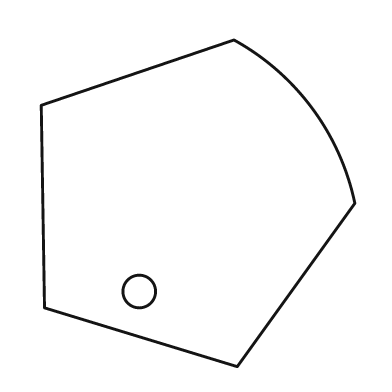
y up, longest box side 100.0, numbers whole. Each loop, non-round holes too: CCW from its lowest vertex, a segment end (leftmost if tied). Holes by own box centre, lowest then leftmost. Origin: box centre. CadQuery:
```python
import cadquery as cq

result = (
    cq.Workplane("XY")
    .moveTo(12.0, -50.0)
    .lineTo(48.0, 0.0)
    .threePointArc((35.0, 29.0), (11.0, 50.0))
    .lineTo(-48.0, 30.0)
    .lineTo(-47.0, -32.0)
    .close()
    .moveTo(-18.0, -27.0)
    .circle(5.0)
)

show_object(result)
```